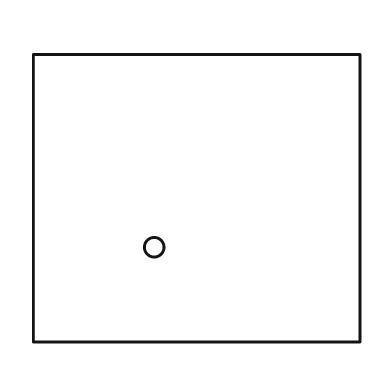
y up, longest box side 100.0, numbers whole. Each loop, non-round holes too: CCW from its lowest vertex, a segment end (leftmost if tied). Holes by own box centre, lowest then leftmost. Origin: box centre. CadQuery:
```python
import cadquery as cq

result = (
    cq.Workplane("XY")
    .moveTo(-50.0, -44.0)
    .lineTo(50.0, -44.0)
    .lineTo(50.0, 44.0)
    .lineTo(-50.0, 44.0)
    .close()
    .moveTo(-13.0, -15.0)
    .circle(3.0)
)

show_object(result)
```